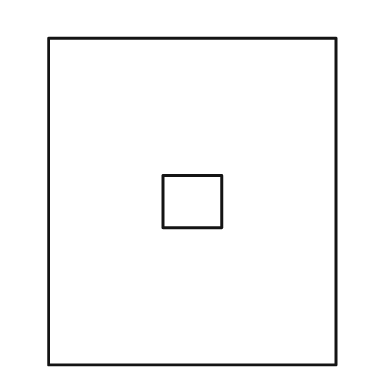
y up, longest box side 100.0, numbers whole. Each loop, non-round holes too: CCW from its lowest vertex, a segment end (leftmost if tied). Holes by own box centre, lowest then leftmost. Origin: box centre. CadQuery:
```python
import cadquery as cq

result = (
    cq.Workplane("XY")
    .moveTo(-44.0, -50.0)
    .lineTo(44.0, -50.0)
    .lineTo(44.0, 50.0)
    .lineTo(-44.0, 50.0)
    .close()
    .moveTo(-9.0, -8.0)
    .lineTo(9.0, -8.0)
    .lineTo(9.0, 8.0)
    .lineTo(-9.0, 8.0)
    .close()
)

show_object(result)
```